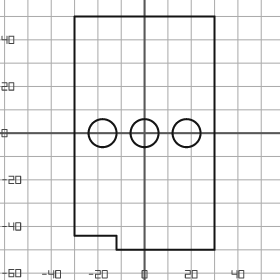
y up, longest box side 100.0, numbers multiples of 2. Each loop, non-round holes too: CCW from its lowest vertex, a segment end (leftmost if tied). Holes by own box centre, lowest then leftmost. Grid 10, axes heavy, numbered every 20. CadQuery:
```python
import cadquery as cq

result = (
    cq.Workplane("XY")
    .moveTo(-12.0, -50.0)
    .lineTo(30.0, -50.0)
    .lineTo(30.0, 50.0)
    .lineTo(-30.0, 50.0)
    .lineTo(-30.0, -44.0)
    .lineTo(-12.0, -44.0)
    .close()
    .moveTo(-18.0, 0.0)
    .circle(6.0)
    .moveTo(0.0, 0.0)
    .circle(6.0)
    .moveTo(18.0, 0.0)
    .circle(6.0)
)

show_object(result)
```